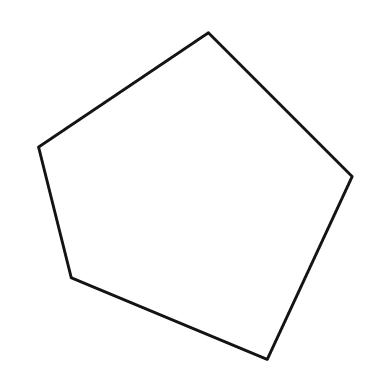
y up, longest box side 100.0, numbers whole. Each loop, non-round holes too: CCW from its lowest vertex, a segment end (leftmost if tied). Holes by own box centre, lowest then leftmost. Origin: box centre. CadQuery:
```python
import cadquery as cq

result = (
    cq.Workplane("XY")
    .moveTo(22.0, -50.0)
    .lineTo(48.0, 6.0)
    .lineTo(4.0, 50.0)
    .lineTo(-48.0, 15.0)
    .lineTo(-38.0, -25.0)
    .close()
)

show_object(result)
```